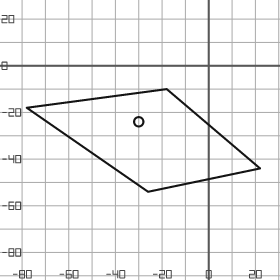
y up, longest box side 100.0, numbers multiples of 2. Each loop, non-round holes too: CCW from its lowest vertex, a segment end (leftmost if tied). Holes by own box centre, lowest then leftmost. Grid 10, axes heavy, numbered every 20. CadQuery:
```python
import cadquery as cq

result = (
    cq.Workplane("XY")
    .moveTo(-26.0, -54.0)
    .lineTo(22.0, -44.0)
    .lineTo(-18.0, -10.0)
    .lineTo(-78.0, -18.0)
    .close()
    .moveTo(-30.0, -24.0)
    .circle(2.0)
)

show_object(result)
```